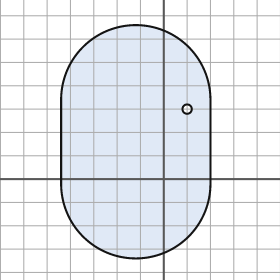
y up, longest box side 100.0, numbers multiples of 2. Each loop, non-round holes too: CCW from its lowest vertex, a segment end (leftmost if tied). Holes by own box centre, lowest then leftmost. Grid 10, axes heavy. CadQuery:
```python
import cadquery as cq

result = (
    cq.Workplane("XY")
    .moveTo(-44.0, -2.0)
    .threePointArc((-12.0, -34.0), (20.0, -2.0))
    .lineTo(20.0, 34.0)
    .threePointArc((-12.0, 66.0), (-44.0, 34.0))
    .close()
    .moveTo(10.0, 30.0)
    .circle(2.0)
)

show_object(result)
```